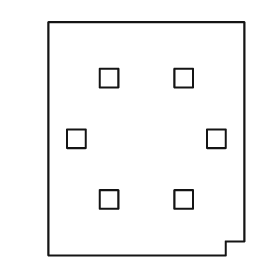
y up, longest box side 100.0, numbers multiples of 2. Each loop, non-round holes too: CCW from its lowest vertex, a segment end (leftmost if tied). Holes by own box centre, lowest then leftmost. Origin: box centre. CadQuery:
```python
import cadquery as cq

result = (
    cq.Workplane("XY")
    .moveTo(-42.0, -50.0)
    .lineTo(34.0, -50.0)
    .lineTo(34.0, -44.0)
    .lineTo(42.0, -44.0)
    .lineTo(42.0, 50.0)
    .lineTo(-42.0, 50.0)
    .close()
    .moveTo(-20.0, -30.0)
    .lineTo(-12.0, -30.0)
    .lineTo(-12.0, -22.0)
    .lineTo(-20.0, -22.0)
    .close()
    .moveTo(12.0, -30.0)
    .lineTo(20.0, -30.0)
    .lineTo(20.0, -22.0)
    .lineTo(12.0, -22.0)
    .close()
    .moveTo(-34.0, -4.0)
    .lineTo(-26.0, -4.0)
    .lineTo(-26.0, 4.0)
    .lineTo(-34.0, 4.0)
    .close()
    .moveTo(26.0, -4.0)
    .lineTo(34.0, -4.0)
    .lineTo(34.0, 4.0)
    .lineTo(26.0, 4.0)
    .close()
    .moveTo(-20.0, 22.0)
    .lineTo(-12.0, 22.0)
    .lineTo(-12.0, 30.0)
    .lineTo(-20.0, 30.0)
    .close()
    .moveTo(12.0, 22.0)
    .lineTo(20.0, 22.0)
    .lineTo(20.0, 30.0)
    .lineTo(12.0, 30.0)
    .close()
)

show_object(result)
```